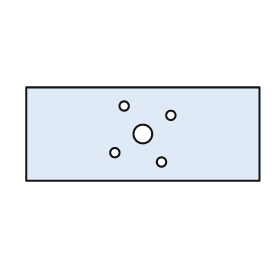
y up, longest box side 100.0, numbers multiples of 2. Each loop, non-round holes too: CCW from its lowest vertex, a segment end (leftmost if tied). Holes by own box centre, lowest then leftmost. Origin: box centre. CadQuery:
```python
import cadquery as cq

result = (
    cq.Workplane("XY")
    .moveTo(-50.0, -20.0)
    .lineTo(50.0, -20.0)
    .lineTo(50.0, 20.0)
    .lineTo(-50.0, 20.0)
    .close()
    .moveTo(8.0, -12.0)
    .circle(2.0)
    .moveTo(-12.0, -8.0)
    .circle(2.0)
    .moveTo(0.0, 0.0)
    .circle(4.0)
    .moveTo(12.0, 8.0)
    .circle(2.0)
    .moveTo(-8.0, 12.0)
    .circle(2.0)
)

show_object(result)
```